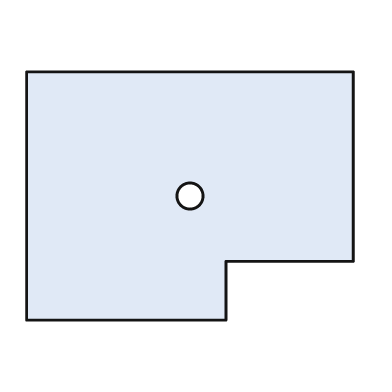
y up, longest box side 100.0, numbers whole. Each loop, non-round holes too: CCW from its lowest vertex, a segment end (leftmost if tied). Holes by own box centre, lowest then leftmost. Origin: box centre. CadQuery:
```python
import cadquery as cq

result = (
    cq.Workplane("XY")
    .moveTo(-50.0, -38.0)
    .lineTo(11.0, -38.0)
    .lineTo(11.0, -20.0)
    .lineTo(50.0, -20.0)
    .lineTo(50.0, 38.0)
    .lineTo(-50.0, 38.0)
    .close()
    .moveTo(0.0, 0.0)
    .circle(4.0)
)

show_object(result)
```